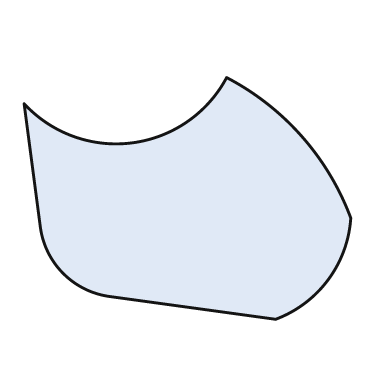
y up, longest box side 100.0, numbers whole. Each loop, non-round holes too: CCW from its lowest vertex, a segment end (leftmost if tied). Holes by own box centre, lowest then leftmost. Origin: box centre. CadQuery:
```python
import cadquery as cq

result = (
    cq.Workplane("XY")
    .moveTo(27.0, -37.0)
    .threePointArc((43.0, -25.0), (50.0, -6.0))
    .threePointArc((35.0, 19.0), (12.0, 37.0))
    .threePointArc((-17.0, 17.0), (-50.0, 29.0))
    .lineTo(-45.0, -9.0)
    .threePointArc((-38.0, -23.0), (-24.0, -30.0))
    .close()
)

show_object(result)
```